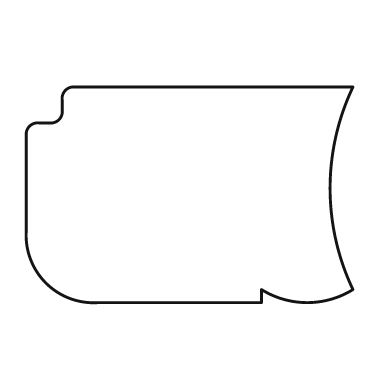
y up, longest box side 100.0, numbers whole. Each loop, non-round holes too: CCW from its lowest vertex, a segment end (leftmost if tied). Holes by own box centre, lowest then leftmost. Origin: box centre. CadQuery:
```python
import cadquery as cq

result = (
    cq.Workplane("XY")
    .moveTo(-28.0, -33.0)
    .lineTo(22.0, -33.0)
    .lineTo(22.0, -29.0)
    .threePointArc((36.0, -33.0), (50.0, -29.0))
    .threePointArc((43.0, 2.0), (50.0, 33.0))
    .lineTo(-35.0, 33.0)
    .threePointArc((-38.0, 32.0), (-39.0, 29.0))
    .lineTo(-39.0, 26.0)
    .threePointArc((-40.0, 23.0), (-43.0, 22.0))
    .lineTo(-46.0, 22.0)
    .threePointArc((-49.0, 21.0), (-50.0, 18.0))
    .lineTo(-50.0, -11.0)
    .threePointArc((-44.0, -27.0), (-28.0, -33.0))
    .close()
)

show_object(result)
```